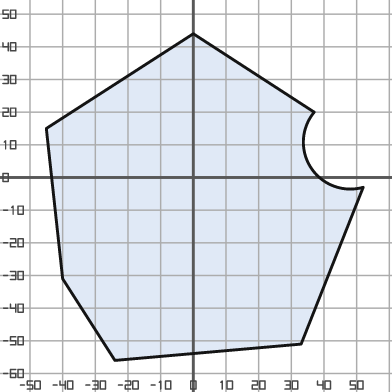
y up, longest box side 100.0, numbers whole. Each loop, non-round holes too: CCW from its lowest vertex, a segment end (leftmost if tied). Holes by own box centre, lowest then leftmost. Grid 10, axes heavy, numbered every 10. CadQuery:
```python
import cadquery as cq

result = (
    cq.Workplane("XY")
    .moveTo(-24.0, -56.0)
    .lineTo(33.0, -51.0)
    .lineTo(52.0, -3.0)
    .threePointArc((36.0, 3.0), (37.0, 20.0))
    .lineTo(0.0, 44.0)
    .lineTo(-45.0, 15.0)
    .lineTo(-40.0, -31.0)
    .close()
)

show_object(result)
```